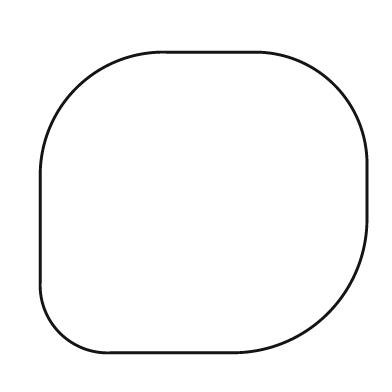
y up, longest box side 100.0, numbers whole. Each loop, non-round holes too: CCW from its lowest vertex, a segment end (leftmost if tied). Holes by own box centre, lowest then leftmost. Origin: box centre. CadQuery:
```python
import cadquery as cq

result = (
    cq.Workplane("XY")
    .moveTo(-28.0, -46.0)
    .lineTo(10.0, -46.0)
    .threePointArc((38.0, -34.0), (50.0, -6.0))
    .lineTo(50.0, 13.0)
    .threePointArc((40.0, 36.0), (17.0, 46.0))
    .lineTo(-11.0, 46.0)
    .threePointArc((-39.0, 35.0), (-50.0, 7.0))
    .lineTo(-50.0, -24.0)
    .threePointArc((-44.0, -40.0), (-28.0, -46.0))
    .close()
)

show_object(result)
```